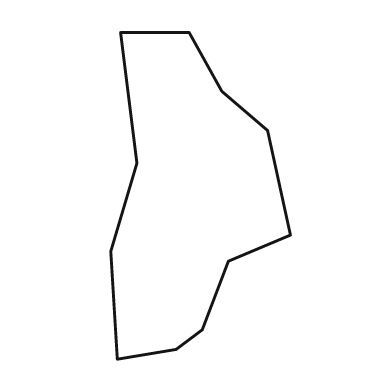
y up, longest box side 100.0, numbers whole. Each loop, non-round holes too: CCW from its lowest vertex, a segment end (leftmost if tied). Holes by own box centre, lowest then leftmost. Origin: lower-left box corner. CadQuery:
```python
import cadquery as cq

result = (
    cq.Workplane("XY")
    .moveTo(2.0, 0.0)
    .lineTo(20.0, 3.0)
    .lineTo(28.0, 9.0)
    .lineTo(36.0, 30.0)
    .lineTo(55.0, 38.0)
    .lineTo(48.0, 70.0)
    .lineTo(34.0, 82.0)
    .lineTo(24.0, 100.0)
    .lineTo(3.0, 100.0)
    .lineTo(8.0, 60.0)
    .lineTo(0.0, 33.0)
    .close()
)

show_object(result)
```